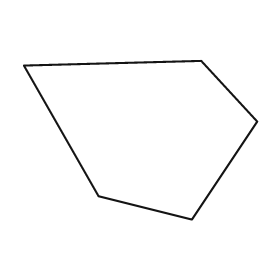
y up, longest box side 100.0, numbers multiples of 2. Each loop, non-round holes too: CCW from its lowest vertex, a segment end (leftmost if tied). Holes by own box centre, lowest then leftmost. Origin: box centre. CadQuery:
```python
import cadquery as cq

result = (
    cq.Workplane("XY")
    .moveTo(22.0, -34.0)
    .lineTo(50.0, 8.0)
    .lineTo(26.0, 34.0)
    .lineTo(-50.0, 32.0)
    .lineTo(-18.0, -24.0)
    .close()
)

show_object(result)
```